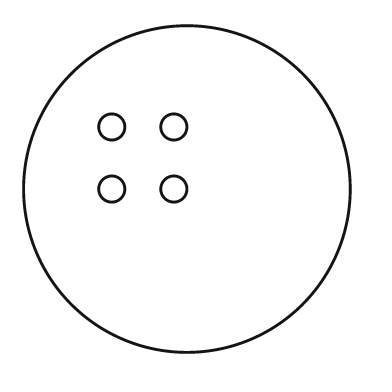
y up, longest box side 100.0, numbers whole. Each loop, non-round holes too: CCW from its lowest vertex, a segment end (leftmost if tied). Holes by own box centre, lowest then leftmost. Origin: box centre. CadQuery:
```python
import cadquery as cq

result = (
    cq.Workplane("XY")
    .moveTo(0.0, 0.0)
    .circle(50.0)
    .moveTo(-23.0, 0.0)
    .circle(4.0)
    .moveTo(-4.0, 0.0)
    .circle(4.0)
    .moveTo(-23.0, 19.0)
    .circle(4.0)
    .moveTo(-4.0, 19.0)
    .circle(4.0)
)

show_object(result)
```